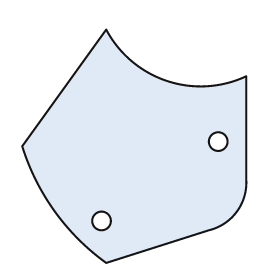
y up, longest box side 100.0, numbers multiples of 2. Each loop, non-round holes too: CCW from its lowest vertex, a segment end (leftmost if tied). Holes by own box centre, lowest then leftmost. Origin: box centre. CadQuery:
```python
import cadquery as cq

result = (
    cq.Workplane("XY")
    .moveTo(-12.0, -50.0)
    .lineTo(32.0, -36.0)
    .threePointArc((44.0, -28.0), (48.0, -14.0))
    .lineTo(48.0, 30.0)
    .threePointArc((14.0, 28.0), (-12.0, 50.0))
    .lineTo(-48.0, 0.0)
    .threePointArc((-34.0, -28.0), (-12.0, -50.0))
    .close()
    .moveTo(-14.0, -32.0)
    .circle(4.0)
    .moveTo(36.0, 2.0)
    .circle(4.0)
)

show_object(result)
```